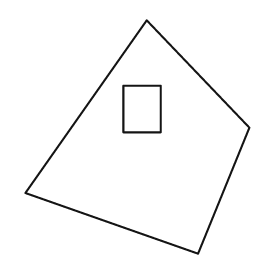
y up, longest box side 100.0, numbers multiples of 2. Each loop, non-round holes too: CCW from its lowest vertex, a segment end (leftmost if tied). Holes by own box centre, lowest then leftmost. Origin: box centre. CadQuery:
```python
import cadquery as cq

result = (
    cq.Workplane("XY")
    .moveTo(26.0, -50.0)
    .lineTo(48.0, 4.0)
    .lineTo(4.0, 50.0)
    .lineTo(-48.0, -24.0)
    .close()
    .moveTo(-6.0, 2.0)
    .lineTo(10.0, 2.0)
    .lineTo(10.0, 22.0)
    .lineTo(-6.0, 22.0)
    .close()
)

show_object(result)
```